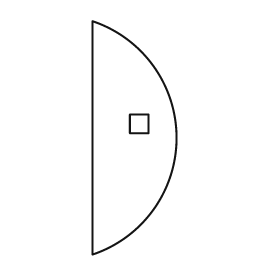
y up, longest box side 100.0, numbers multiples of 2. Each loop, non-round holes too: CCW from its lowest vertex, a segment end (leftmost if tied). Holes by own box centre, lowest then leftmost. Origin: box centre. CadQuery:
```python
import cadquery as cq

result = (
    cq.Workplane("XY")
    .moveTo(-18.0, -50.0)
    .threePointArc((18.0, 0.0), (-18.0, 50.0))
    .close()
    .moveTo(-2.0, 2.0)
    .lineTo(6.0, 2.0)
    .lineTo(6.0, 10.0)
    .lineTo(-2.0, 10.0)
    .close()
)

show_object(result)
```